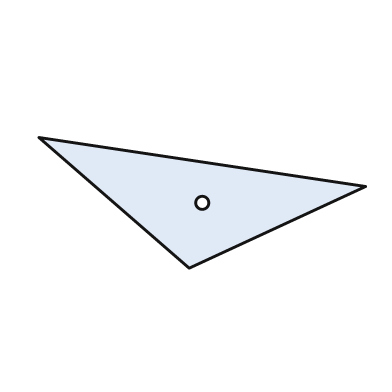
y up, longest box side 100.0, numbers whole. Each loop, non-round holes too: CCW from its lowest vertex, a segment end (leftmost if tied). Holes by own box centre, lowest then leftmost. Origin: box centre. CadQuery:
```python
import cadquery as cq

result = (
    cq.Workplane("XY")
    .moveTo(-4.0, -20.0)
    .lineTo(50.0, 5.0)
    .lineTo(-50.0, 20.0)
    .close()
    .moveTo(0.0, 0.0)
    .circle(2.0)
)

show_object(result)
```